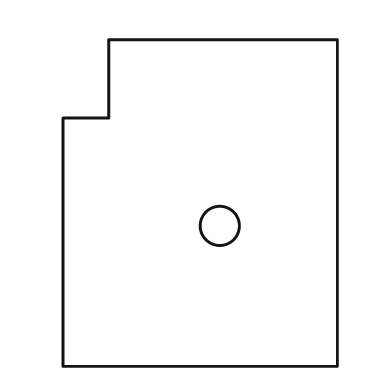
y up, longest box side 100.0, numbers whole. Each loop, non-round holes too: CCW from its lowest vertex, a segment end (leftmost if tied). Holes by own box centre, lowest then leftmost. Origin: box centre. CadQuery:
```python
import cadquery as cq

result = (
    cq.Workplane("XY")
    .moveTo(-42.0, -50.0)
    .lineTo(42.0, -50.0)
    .lineTo(42.0, 50.0)
    .lineTo(-28.0, 50.0)
    .lineTo(-28.0, 26.0)
    .lineTo(-42.0, 26.0)
    .close()
    .moveTo(6.0, -7.0)
    .circle(6.0)
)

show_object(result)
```